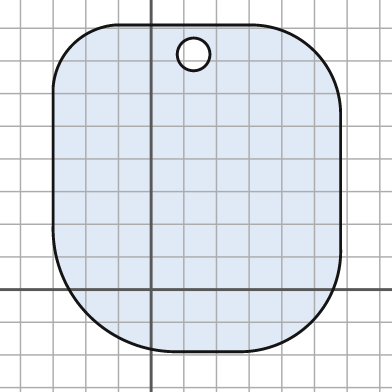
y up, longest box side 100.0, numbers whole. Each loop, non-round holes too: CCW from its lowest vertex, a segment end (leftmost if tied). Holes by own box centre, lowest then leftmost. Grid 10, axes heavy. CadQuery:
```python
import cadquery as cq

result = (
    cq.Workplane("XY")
    .moveTo(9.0, -19.0)
    .lineTo(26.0, -19.0)
    .threePointArc((49.0, -10.0), (58.0, 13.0))
    .lineTo(58.0, 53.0)
    .threePointArc((50.0, 73.0), (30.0, 81.0))
    .lineTo(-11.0, 81.0)
    .threePointArc((-24.0, 75.0), (-30.0, 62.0))
    .lineTo(-30.0, 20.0)
    .threePointArc((-19.0, -8.0), (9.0, -19.0))
    .close()
    .moveTo(13.0, 72.0)
    .circle(5.0)
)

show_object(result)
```